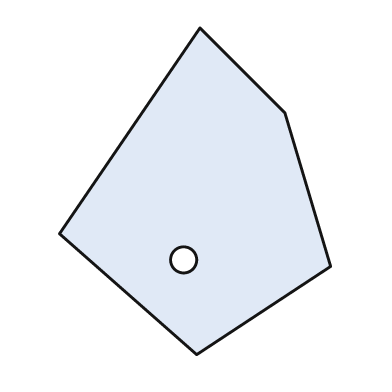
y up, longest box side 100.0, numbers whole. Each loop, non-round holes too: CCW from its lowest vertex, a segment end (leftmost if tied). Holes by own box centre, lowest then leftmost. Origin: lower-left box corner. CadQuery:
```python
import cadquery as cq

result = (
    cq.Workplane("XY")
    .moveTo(42.0, 0.0)
    .lineTo(83.0, 27.0)
    .lineTo(69.0, 74.0)
    .lineTo(43.0, 100.0)
    .lineTo(0.0, 37.0)
    .close()
    .moveTo(38.0, 29.0)
    .circle(4.0)
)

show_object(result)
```